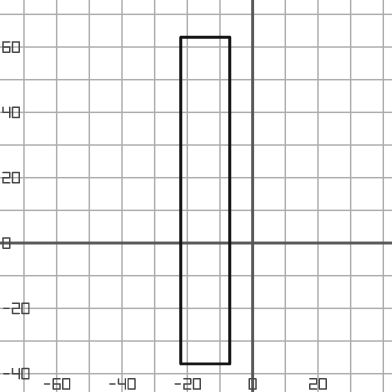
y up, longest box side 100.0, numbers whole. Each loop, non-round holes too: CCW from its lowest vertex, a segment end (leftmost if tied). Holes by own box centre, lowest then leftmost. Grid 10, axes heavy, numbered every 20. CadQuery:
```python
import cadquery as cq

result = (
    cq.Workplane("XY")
    .moveTo(-22.0, -37.0)
    .lineTo(-7.0, -37.0)
    .lineTo(-7.0, 63.0)
    .lineTo(-22.0, 63.0)
    .close()
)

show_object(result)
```